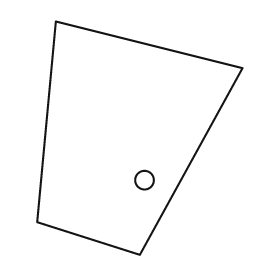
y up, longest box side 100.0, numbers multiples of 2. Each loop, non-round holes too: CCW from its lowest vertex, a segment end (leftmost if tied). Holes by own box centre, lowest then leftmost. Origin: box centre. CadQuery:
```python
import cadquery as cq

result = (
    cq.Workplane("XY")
    .moveTo(0.0, -50.0)
    .lineTo(44.0, 30.0)
    .lineTo(-36.0, 50.0)
    .lineTo(-44.0, -36.0)
    .close()
    .moveTo(2.0, -18.0)
    .circle(4.0)
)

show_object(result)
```